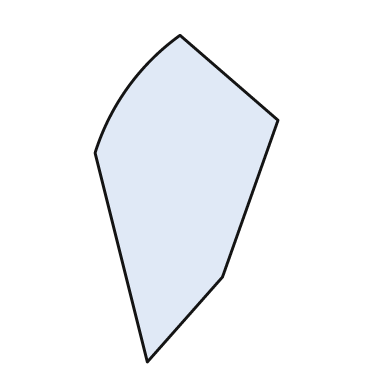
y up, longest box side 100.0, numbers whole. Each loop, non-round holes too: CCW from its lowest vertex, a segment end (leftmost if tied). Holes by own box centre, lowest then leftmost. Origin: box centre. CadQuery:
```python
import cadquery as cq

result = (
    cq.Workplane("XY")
    .moveTo(-12.0, -50.0)
    .lineTo(11.0, -24.0)
    .lineTo(28.0, 24.0)
    .lineTo(-2.0, 50.0)
    .threePointArc((-18.0, 34.0), (-28.0, 14.0))
    .close()
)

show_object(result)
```